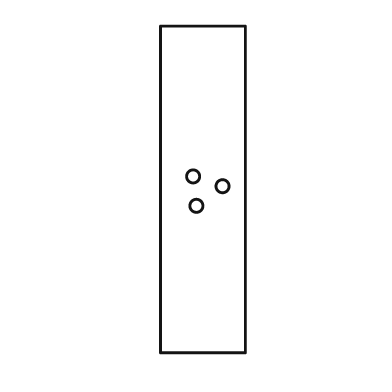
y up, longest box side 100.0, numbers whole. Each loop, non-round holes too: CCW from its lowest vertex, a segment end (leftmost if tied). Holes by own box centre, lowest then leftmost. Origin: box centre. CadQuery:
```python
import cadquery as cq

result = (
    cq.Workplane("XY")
    .moveTo(-13.0, -50.0)
    .lineTo(13.0, -50.0)
    .lineTo(13.0, 50.0)
    .lineTo(-13.0, 50.0)
    .close()
    .moveTo(-2.0, -5.0)
    .circle(2.0)
    .moveTo(6.0, 1.0)
    .circle(2.0)
    .moveTo(-3.0, 4.0)
    .circle(2.0)
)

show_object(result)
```